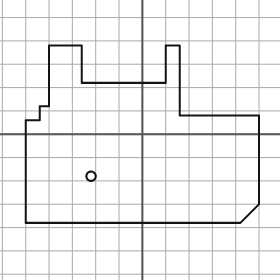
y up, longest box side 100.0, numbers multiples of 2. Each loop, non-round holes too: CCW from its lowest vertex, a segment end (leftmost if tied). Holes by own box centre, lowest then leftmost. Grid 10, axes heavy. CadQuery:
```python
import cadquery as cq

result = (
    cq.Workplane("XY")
    .moveTo(-50.0, -38.0)
    .lineTo(42.0, -38.0)
    .lineTo(50.0, -30.0)
    .lineTo(50.0, 8.0)
    .lineTo(16.0, 8.0)
    .lineTo(16.0, 38.0)
    .lineTo(10.0, 38.0)
    .lineTo(10.0, 22.0)
    .lineTo(-26.0, 22.0)
    .lineTo(-26.0, 38.0)
    .lineTo(-40.0, 38.0)
    .lineTo(-40.0, 12.0)
    .lineTo(-44.0, 12.0)
    .lineTo(-44.0, 6.0)
    .lineTo(-50.0, 6.0)
    .close()
    .moveTo(-22.0, -18.0)
    .circle(2.0)
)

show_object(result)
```